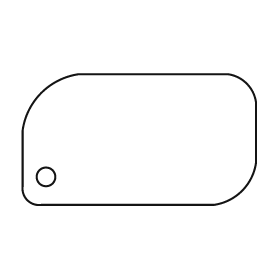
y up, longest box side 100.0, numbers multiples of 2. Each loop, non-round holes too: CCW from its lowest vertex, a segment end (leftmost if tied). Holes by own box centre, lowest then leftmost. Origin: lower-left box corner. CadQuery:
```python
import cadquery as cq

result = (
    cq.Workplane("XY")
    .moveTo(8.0, 0.0)
    .lineTo(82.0, 0.0)
    .threePointArc((94.0, 6.0), (100.0, 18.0))
    .lineTo(100.0, 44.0)
    .threePointArc((96.0, 52.0), (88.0, 56.0))
    .lineTo(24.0, 56.0)
    .threePointArc((8.0, 48.0), (0.0, 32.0))
    .lineTo(0.0, 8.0)
    .threePointArc((2.0, 2.0), (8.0, 0.0))
    .close()
    .moveTo(10.0, 12.0)
    .circle(4.0)
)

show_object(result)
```